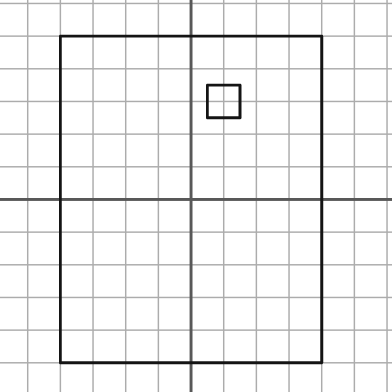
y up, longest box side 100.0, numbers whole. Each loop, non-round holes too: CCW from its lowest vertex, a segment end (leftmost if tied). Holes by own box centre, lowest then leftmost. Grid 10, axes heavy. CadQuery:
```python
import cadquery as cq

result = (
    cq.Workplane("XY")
    .moveTo(-40.0, -50.0)
    .lineTo(40.0, -50.0)
    .lineTo(40.0, 50.0)
    .lineTo(-40.0, 50.0)
    .close()
    .moveTo(5.0, 25.0)
    .lineTo(15.0, 25.0)
    .lineTo(15.0, 35.0)
    .lineTo(5.0, 35.0)
    .close()
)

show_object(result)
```